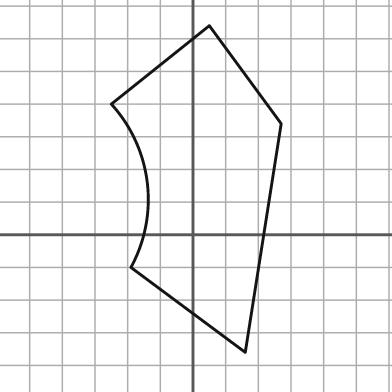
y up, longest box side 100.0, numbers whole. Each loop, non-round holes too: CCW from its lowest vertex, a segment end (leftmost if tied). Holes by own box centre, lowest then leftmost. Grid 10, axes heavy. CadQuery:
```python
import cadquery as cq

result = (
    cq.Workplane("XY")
    .moveTo(16.0, -36.0)
    .lineTo(27.0, 34.0)
    .lineTo(5.0, 64.0)
    .lineTo(-25.0, 40.0)
    .threePointArc((-14.0, 16.0), (-19.0, -10.0))
    .close()
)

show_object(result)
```